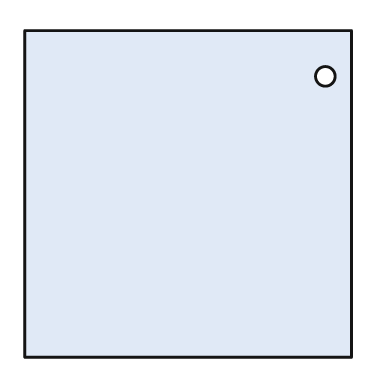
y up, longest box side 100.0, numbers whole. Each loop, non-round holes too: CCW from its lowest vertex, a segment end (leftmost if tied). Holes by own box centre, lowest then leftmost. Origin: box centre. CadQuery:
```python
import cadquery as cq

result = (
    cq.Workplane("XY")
    .moveTo(-50.0, -50.0)
    .lineTo(50.0, -50.0)
    .lineTo(50.0, 50.0)
    .lineTo(-50.0, 50.0)
    .close()
    .moveTo(42.0, 36.0)
    .circle(3.0)
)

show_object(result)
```